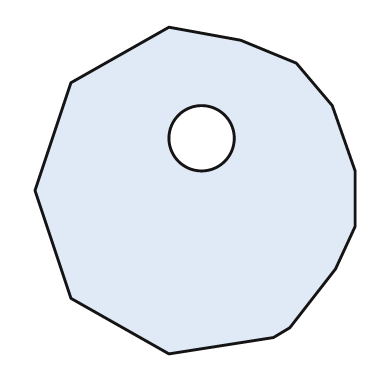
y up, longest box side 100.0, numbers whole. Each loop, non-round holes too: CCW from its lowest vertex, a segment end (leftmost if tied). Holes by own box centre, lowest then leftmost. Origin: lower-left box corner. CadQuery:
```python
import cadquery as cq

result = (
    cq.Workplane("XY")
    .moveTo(41.0, 0.0)
    .lineTo(73.0, 5.0)
    .lineTo(78.0, 8.0)
    .lineTo(92.0, 26.0)
    .lineTo(98.0, 39.0)
    .lineTo(98.0, 56.0)
    .lineTo(91.0, 76.0)
    .lineTo(80.0, 89.0)
    .lineTo(63.0, 96.0)
    .lineTo(41.0, 100.0)
    .lineTo(11.0, 83.0)
    .lineTo(0.0, 50.0)
    .lineTo(11.0, 17.0)
    .close()
    .moveTo(51.0, 66.0)
    .circle(10.0)
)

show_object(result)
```